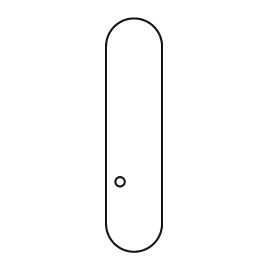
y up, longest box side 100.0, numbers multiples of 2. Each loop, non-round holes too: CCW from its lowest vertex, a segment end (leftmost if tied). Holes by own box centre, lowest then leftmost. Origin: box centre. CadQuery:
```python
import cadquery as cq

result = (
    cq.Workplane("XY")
    .moveTo(-12.0, -38.0)
    .threePointArc((0.0, -50.0), (12.0, -38.0))
    .lineTo(12.0, 38.0)
    .threePointArc((0.0, 50.0), (-12.0, 38.0))
    .close()
    .moveTo(-6.0, -20.0)
    .circle(2.0)
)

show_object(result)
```